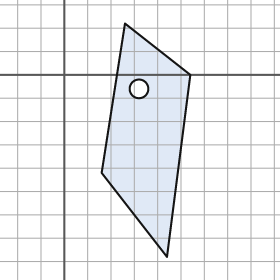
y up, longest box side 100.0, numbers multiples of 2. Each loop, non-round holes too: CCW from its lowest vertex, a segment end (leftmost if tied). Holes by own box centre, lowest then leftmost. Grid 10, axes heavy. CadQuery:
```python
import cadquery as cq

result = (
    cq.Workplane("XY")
    .moveTo(44.0, -78.0)
    .lineTo(54.0, 0.0)
    .lineTo(26.0, 22.0)
    .lineTo(16.0, -42.0)
    .close()
    .moveTo(32.0, -6.0)
    .circle(4.0)
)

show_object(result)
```